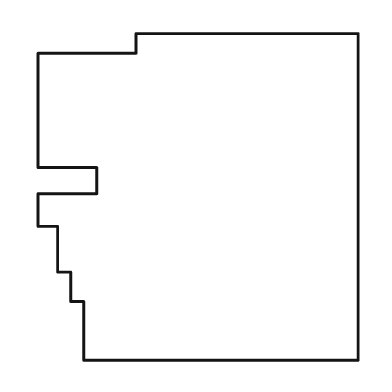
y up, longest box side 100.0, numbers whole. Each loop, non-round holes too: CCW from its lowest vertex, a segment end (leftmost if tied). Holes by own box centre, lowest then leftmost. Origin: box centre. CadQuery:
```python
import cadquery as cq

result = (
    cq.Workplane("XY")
    .moveTo(-35.0, -50.0)
    .lineTo(49.0, -50.0)
    .lineTo(49.0, 50.0)
    .lineTo(-19.0, 50.0)
    .lineTo(-19.0, 44.0)
    .lineTo(-49.0, 44.0)
    .lineTo(-49.0, 9.0)
    .lineTo(-31.0, 9.0)
    .lineTo(-31.0, 1.0)
    .lineTo(-49.0, 1.0)
    .lineTo(-49.0, -9.0)
    .lineTo(-43.0, -9.0)
    .lineTo(-43.0, -23.0)
    .lineTo(-39.0, -23.0)
    .lineTo(-39.0, -32.0)
    .lineTo(-35.0, -32.0)
    .close()
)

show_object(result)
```